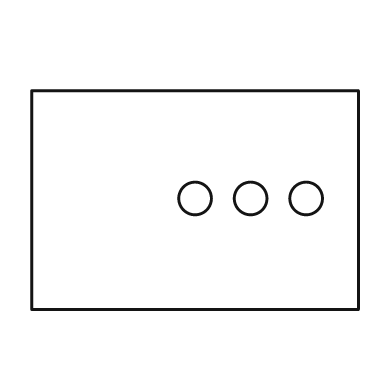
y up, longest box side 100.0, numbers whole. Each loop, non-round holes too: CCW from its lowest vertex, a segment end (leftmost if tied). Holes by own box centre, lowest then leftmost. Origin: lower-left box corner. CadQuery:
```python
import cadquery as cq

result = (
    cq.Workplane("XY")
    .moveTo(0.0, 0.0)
    .lineTo(100.0, 0.0)
    .lineTo(100.0, 67.0)
    .lineTo(0.0, 67.0)
    .close()
    .moveTo(50.0, 34.0)
    .circle(5.0)
    .moveTo(67.0, 34.0)
    .circle(5.0)
    .moveTo(84.0, 34.0)
    .circle(5.0)
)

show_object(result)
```